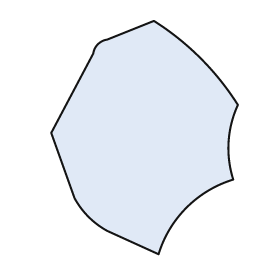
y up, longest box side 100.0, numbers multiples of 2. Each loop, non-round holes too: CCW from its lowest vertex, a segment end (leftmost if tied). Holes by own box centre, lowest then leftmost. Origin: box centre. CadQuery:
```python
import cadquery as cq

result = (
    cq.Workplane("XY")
    .moveTo(6.0, -50.0)
    .threePointArc((18.0, -30.0), (38.0, -18.0))
    .threePointArc((36.0, -2.0), (40.0, 14.0))
    .threePointArc((24.0, 34.0), (4.0, 50.0))
    .lineTo(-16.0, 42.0)
    .threePointArc((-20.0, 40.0), (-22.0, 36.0))
    .lineTo(-40.0, 2.0)
    .lineTo(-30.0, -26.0)
    .threePointArc((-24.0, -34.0), (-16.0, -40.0))
    .close()
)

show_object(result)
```